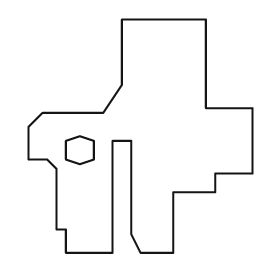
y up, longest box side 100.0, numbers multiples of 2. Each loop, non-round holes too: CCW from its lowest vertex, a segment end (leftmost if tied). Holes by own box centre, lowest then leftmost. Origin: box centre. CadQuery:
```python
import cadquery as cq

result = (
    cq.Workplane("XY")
    .moveTo(-32.0, -50.0)
    .lineTo(-12.0, -50.0)
    .lineTo(-12.0, -2.0)
    .lineTo(-4.0, -2.0)
    .lineTo(-4.0, -42.0)
    .lineTo(0.0, -50.0)
    .lineTo(14.0, -50.0)
    .lineTo(14.0, -24.0)
    .lineTo(32.0, -24.0)
    .lineTo(32.0, -16.0)
    .lineTo(48.0, -16.0)
    .lineTo(48.0, 12.0)
    .lineTo(28.0, 12.0)
    .lineTo(28.0, 50.0)
    .lineTo(-8.0, 50.0)
    .lineTo(-8.0, 22.0)
    .lineTo(-16.0, 10.0)
    .lineTo(-42.0, 10.0)
    .lineTo(-48.0, 4.0)
    .lineTo(-48.0, -10.0)
    .lineTo(-40.0, -10.0)
    .lineTo(-36.0, -14.0)
    .lineTo(-36.0, -40.0)
    .lineTo(-32.0, -40.0)
    .close()
    .moveTo(-26.0, -12.0)
    .lineTo(-20.0, -10.0)
    .lineTo(-20.0, -2.0)
    .lineTo(-26.0, 0.0)
    .lineTo(-32.0, -2.0)
    .lineTo(-32.0, -10.0)
    .close()
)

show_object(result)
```